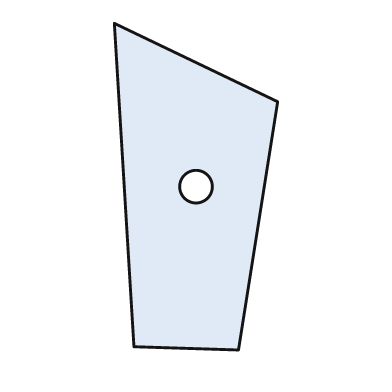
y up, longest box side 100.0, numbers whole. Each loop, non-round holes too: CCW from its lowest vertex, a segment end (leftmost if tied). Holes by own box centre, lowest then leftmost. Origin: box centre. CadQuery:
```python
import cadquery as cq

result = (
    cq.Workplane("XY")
    .moveTo(13.0, -50.0)
    .lineTo(25.0, 26.0)
    .lineTo(-25.0, 50.0)
    .lineTo(-19.0, -49.0)
    .close()
    .moveTo(0.0, 0.0)
    .circle(5.0)
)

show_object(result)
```